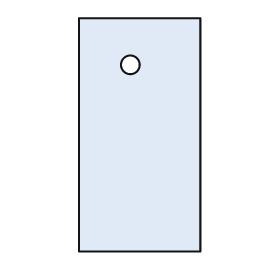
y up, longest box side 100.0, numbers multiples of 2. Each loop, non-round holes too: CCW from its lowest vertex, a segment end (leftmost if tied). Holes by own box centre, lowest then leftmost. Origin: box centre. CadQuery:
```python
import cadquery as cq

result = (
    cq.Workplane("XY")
    .moveTo(-26.0, -50.0)
    .lineTo(26.0, -50.0)
    .lineTo(26.0, 50.0)
    .lineTo(-26.0, 50.0)
    .close()
    .moveTo(-4.0, 30.0)
    .circle(4.0)
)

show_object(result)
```